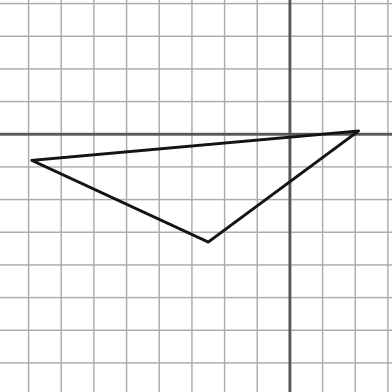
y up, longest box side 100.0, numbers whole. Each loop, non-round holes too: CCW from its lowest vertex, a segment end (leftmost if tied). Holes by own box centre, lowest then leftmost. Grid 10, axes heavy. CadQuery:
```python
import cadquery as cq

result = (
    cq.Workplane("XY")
    .moveTo(-25.0, -33.0)
    .lineTo(21.0, 1.0)
    .lineTo(-79.0, -8.0)
    .close()
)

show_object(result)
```